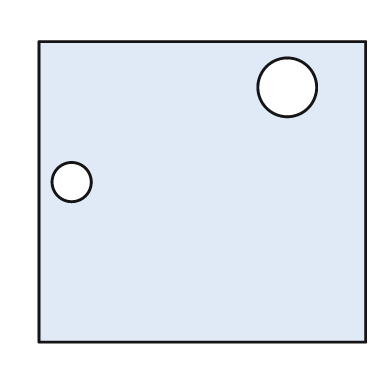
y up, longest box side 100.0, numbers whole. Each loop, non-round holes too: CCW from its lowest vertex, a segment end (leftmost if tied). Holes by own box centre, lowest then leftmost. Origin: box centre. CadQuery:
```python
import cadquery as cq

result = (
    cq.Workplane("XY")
    .moveTo(-50.0, -46.0)
    .lineTo(50.0, -46.0)
    .lineTo(50.0, 46.0)
    .lineTo(-50.0, 46.0)
    .close()
    .moveTo(-40.0, 3.0)
    .circle(6.0)
    .moveTo(26.0, 32.0)
    .circle(9.0)
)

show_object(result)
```